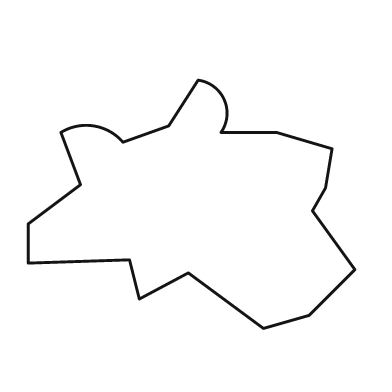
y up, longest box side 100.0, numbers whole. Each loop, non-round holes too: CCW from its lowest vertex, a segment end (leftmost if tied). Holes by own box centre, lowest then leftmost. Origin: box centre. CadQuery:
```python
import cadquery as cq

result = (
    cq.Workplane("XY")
    .moveTo(22.0, -38.0)
    .lineTo(36.0, -34.0)
    .lineTo(50.0, -20.0)
    .lineTo(37.0, -2.0)
    .lineTo(41.0, 5.0)
    .lineTo(43.0, 17.0)
    .lineTo(26.0, 22.0)
    .lineTo(9.0, 22.0)
    .threePointArc((10.0, 32.0), (2.0, 38.0))
    .lineTo(-7.0, 24.0)
    .lineTo(-21.0, 19.0)
    .threePointArc((-30.0, 24.0), (-40.0, 22.0))
    .lineTo(-34.0, 6.0)
    .lineTo(-50.0, -6.0)
    .lineTo(-50.0, -18.0)
    .lineTo(-19.0, -17.0)
    .lineTo(-16.0, -29.0)
    .lineTo(-1.0, -21.0)
    .close()
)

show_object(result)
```